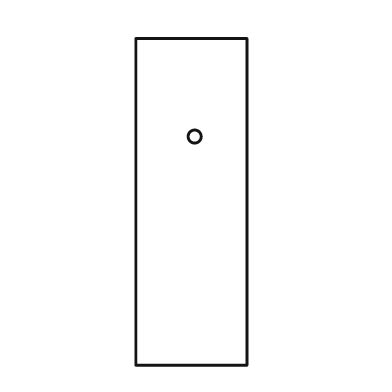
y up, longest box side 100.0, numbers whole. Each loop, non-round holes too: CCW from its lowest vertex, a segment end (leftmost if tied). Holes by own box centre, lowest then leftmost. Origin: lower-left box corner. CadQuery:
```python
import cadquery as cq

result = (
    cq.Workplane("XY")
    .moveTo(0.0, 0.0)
    .lineTo(34.0, 0.0)
    .lineTo(34.0, 100.0)
    .lineTo(0.0, 100.0)
    .close()
    .moveTo(18.0, 70.0)
    .circle(2.0)
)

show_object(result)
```